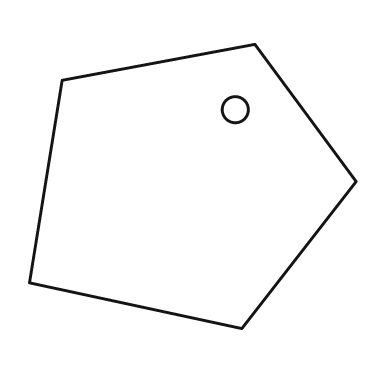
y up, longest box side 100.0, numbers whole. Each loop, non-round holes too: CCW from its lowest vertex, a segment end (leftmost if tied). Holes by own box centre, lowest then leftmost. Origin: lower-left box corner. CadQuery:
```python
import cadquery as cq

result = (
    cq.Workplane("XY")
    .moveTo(65.0, 0.0)
    .lineTo(100.0, 45.0)
    .lineTo(69.0, 87.0)
    .lineTo(10.0, 76.0)
    .lineTo(0.0, 14.0)
    .close()
    .moveTo(63.0, 67.0)
    .circle(4.0)
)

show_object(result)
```